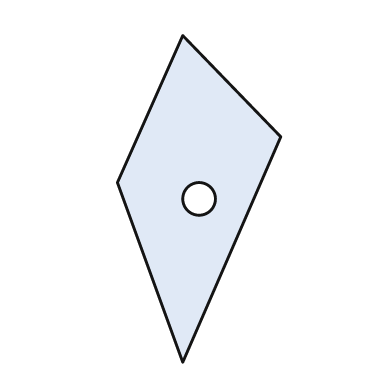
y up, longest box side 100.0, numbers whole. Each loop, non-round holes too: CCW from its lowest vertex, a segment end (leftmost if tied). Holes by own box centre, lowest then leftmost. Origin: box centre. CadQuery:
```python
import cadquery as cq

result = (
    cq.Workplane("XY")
    .moveTo(-5.0, -50.0)
    .lineTo(25.0, 19.0)
    .lineTo(-5.0, 50.0)
    .lineTo(-25.0, 5.0)
    .close()
    .moveTo(0.0, 0.0)
    .circle(5.0)
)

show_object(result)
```